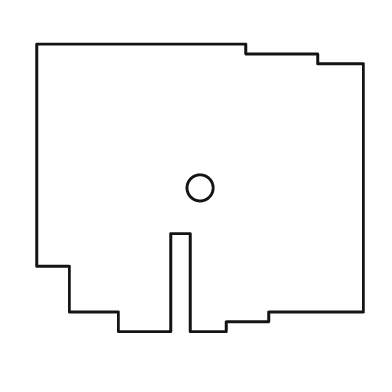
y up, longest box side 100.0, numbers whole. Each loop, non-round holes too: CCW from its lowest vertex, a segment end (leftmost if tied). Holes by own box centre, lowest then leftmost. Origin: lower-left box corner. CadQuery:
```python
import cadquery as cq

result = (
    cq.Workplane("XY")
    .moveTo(25.0, 0.0)
    .lineTo(41.0, 0.0)
    .lineTo(41.0, 30.0)
    .lineTo(47.0, 30.0)
    .lineTo(47.0, 0.0)
    .lineTo(58.0, 0.0)
    .lineTo(58.0, 3.0)
    .lineTo(71.0, 3.0)
    .lineTo(71.0, 6.0)
    .lineTo(100.0, 6.0)
    .lineTo(100.0, 82.0)
    .lineTo(86.0, 82.0)
    .lineTo(86.0, 85.0)
    .lineTo(64.0, 85.0)
    .lineTo(64.0, 88.0)
    .lineTo(0.0, 88.0)
    .lineTo(0.0, 20.0)
    .lineTo(10.0, 20.0)
    .lineTo(10.0, 6.0)
    .lineTo(25.0, 6.0)
    .close()
    .moveTo(50.0, 44.0)
    .circle(4.0)
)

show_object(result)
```